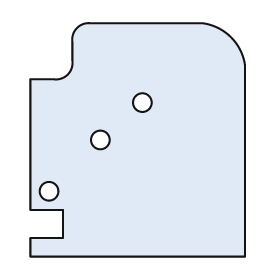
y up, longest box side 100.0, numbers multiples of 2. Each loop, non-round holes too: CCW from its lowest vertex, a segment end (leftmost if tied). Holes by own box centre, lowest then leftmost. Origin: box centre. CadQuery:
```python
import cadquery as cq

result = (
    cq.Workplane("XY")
    .moveTo(-46.0, -50.0)
    .lineTo(46.0, -50.0)
    .lineTo(46.0, 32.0)
    .threePointArc((40.0, 44.0), (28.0, 50.0))
    .lineTo(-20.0, 50.0)
    .threePointArc((-26.0, 48.0), (-28.0, 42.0))
    .lineTo(-28.0, 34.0)
    .threePointArc((-30.0, 28.0), (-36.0, 26.0))
    .lineTo(-46.0, 26.0)
    .lineTo(-46.0, -30.0)
    .lineTo(-32.0, -30.0)
    .lineTo(-32.0, -42.0)
    .lineTo(-46.0, -42.0)
    .close()
    .moveTo(-38.0, -22.0)
    .circle(4.0)
    .moveTo(-16.0, 0.0)
    .circle(4.0)
    .moveTo(2.0, 16.0)
    .circle(4.0)
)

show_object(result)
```